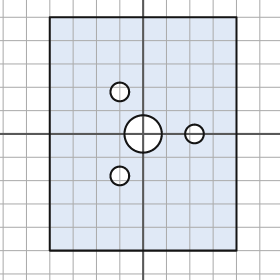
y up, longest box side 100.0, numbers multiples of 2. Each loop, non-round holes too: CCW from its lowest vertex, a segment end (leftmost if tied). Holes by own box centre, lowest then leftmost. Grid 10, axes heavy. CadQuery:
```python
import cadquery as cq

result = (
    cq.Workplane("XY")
    .moveTo(-40.0, -50.0)
    .lineTo(40.0, -50.0)
    .lineTo(40.0, 50.0)
    .lineTo(-40.0, 50.0)
    .close()
    .moveTo(-10.0, -18.0)
    .circle(4.0)
    .moveTo(0.0, 0.0)
    .circle(8.0)
    .moveTo(22.0, 0.0)
    .circle(4.0)
    .moveTo(-10.0, 18.0)
    .circle(4.0)
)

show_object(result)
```